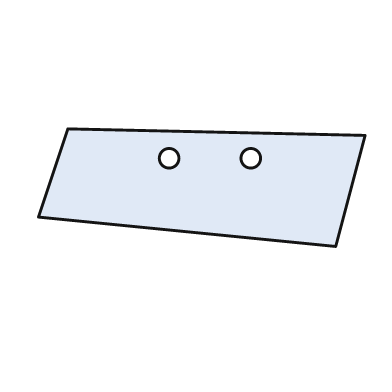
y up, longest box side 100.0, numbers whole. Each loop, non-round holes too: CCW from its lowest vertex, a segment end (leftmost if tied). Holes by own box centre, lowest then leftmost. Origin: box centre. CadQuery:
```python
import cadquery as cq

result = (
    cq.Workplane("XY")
    .moveTo(41.0, -18.0)
    .lineTo(50.0, 16.0)
    .lineTo(-41.0, 18.0)
    .lineTo(-50.0, -9.0)
    .close()
    .moveTo(-10.0, 9.0)
    .circle(3.0)
    .moveTo(15.0, 9.0)
    .circle(3.0)
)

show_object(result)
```